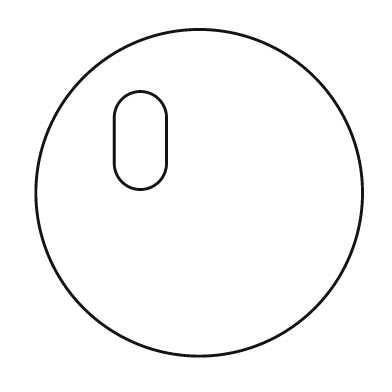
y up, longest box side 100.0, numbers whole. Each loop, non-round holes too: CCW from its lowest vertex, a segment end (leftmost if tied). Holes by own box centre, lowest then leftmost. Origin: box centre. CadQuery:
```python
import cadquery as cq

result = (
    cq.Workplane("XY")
    .moveTo(0.0, 0.0)
    .circle(50.0)
    .moveTo(-26.0, 9.0)
    .threePointArc((-18.0, 1.0), (-10.0, 9.0))
    .lineTo(-10.0, 23.0)
    .threePointArc((-18.0, 31.0), (-26.0, 23.0))
    .close()
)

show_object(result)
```